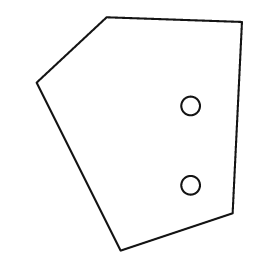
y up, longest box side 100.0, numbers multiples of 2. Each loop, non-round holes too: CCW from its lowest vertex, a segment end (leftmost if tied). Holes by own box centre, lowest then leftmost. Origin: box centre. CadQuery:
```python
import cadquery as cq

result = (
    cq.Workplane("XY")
    .moveTo(-8.0, -50.0)
    .lineTo(40.0, -34.0)
    .lineTo(44.0, 48.0)
    .lineTo(-14.0, 50.0)
    .lineTo(-44.0, 22.0)
    .close()
    .moveTo(22.0, -22.0)
    .circle(4.0)
    .moveTo(22.0, 12.0)
    .circle(4.0)
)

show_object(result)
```